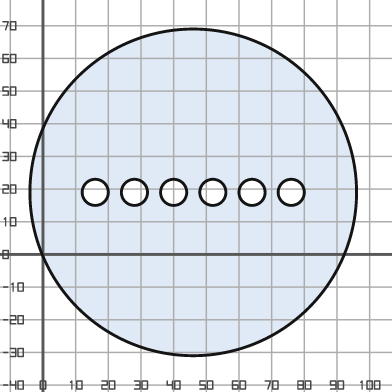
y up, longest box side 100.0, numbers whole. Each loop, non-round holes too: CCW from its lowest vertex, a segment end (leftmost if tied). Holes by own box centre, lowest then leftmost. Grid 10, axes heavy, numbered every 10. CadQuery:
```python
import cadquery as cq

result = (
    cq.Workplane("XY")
    .moveTo(46.0, 19.0)
    .circle(50.0)
    .moveTo(16.0, 19.0)
    .circle(4.0)
    .moveTo(28.0, 19.0)
    .circle(4.0)
    .moveTo(40.0, 19.0)
    .circle(4.0)
    .moveTo(52.0, 19.0)
    .circle(4.0)
    .moveTo(64.0, 19.0)
    .circle(4.0)
    .moveTo(76.0, 19.0)
    .circle(4.0)
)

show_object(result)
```